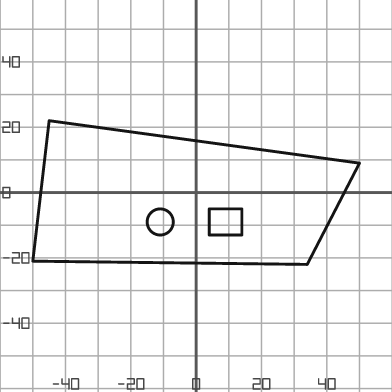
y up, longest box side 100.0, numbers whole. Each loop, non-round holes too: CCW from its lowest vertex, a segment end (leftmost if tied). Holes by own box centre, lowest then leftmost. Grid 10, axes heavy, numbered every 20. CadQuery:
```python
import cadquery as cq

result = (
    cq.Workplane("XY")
    .moveTo(34.0, -22.0)
    .lineTo(50.0, 9.0)
    .lineTo(-45.0, 22.0)
    .lineTo(-50.0, -21.0)
    .close()
    .moveTo(-11.0, -9.0)
    .circle(4.0)
    .moveTo(4.0, -13.0)
    .lineTo(14.0, -13.0)
    .lineTo(14.0, -5.0)
    .lineTo(4.0, -5.0)
    .close()
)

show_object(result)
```